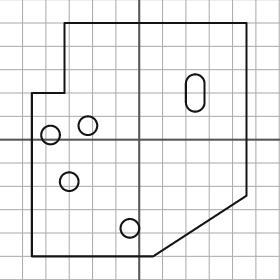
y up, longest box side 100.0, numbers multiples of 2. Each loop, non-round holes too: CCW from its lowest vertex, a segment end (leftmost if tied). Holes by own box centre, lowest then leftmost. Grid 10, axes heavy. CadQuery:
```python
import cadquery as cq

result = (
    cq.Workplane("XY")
    .moveTo(-46.0, -50.0)
    .lineTo(6.0, -50.0)
    .lineTo(46.0, -24.0)
    .lineTo(46.0, 50.0)
    .lineTo(-32.0, 50.0)
    .lineTo(-32.0, 20.0)
    .lineTo(-46.0, 20.0)
    .close()
    .moveTo(-4.0, -38.0)
    .circle(4.0)
    .moveTo(-30.0, -18.0)
    .circle(4.0)
    .moveTo(-38.0, 2.0)
    .circle(4.0)
    .moveTo(-22.0, 6.0)
    .circle(4.0)
    .moveTo(20.0, 16.0)
    .threePointArc((24.0, 12.0), (28.0, 16.0))
    .lineTo(28.0, 24.0)
    .threePointArc((24.0, 28.0), (20.0, 24.0))
    .close()
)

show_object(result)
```